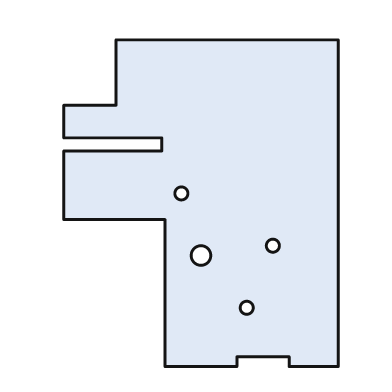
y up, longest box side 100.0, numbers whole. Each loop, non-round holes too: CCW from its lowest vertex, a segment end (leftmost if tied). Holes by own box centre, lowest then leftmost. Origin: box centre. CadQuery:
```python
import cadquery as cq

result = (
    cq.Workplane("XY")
    .moveTo(-11.0, -50.0)
    .lineTo(11.0, -50.0)
    .lineTo(11.0, -47.0)
    .lineTo(27.0, -47.0)
    .lineTo(27.0, -50.0)
    .lineTo(42.0, -50.0)
    .lineTo(42.0, 50.0)
    .lineTo(-26.0, 50.0)
    .lineTo(-26.0, 30.0)
    .lineTo(-42.0, 30.0)
    .lineTo(-42.0, 20.0)
    .lineTo(-12.0, 20.0)
    .lineTo(-12.0, 16.0)
    .lineTo(-42.0, 16.0)
    .lineTo(-42.0, -5.0)
    .lineTo(-11.0, -5.0)
    .close()
    .moveTo(14.0, -32.0)
    .circle(2.0)
    .moveTo(0.0, -16.0)
    .circle(3.0)
    .moveTo(22.0, -13.0)
    .circle(2.0)
    .moveTo(-6.0, 3.0)
    .circle(2.0)
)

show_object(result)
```